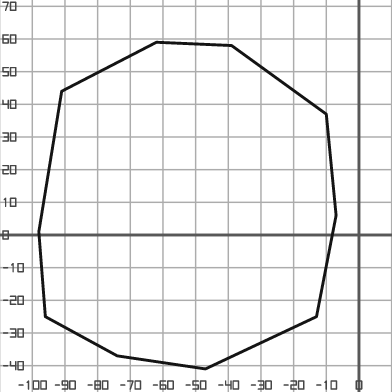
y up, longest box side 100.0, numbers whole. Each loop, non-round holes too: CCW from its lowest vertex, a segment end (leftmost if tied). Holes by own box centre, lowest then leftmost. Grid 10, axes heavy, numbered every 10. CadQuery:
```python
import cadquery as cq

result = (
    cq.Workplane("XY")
    .moveTo(-47.0, -41.0)
    .lineTo(-13.0, -25.0)
    .lineTo(-7.0, 6.0)
    .lineTo(-10.0, 37.0)
    .lineTo(-39.0, 58.0)
    .lineTo(-62.0, 59.0)
    .lineTo(-91.0, 44.0)
    .lineTo(-98.0, 1.0)
    .lineTo(-96.0, -25.0)
    .lineTo(-74.0, -37.0)
    .close()
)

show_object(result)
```